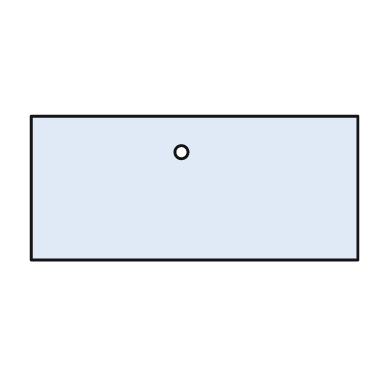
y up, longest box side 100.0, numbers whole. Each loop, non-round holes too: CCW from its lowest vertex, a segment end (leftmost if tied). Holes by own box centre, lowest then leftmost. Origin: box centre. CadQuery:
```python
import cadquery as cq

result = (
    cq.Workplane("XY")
    .moveTo(-50.0, -22.0)
    .lineTo(50.0, -22.0)
    .lineTo(50.0, 22.0)
    .lineTo(-50.0, 22.0)
    .close()
    .moveTo(-4.0, 11.0)
    .circle(2.0)
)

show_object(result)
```